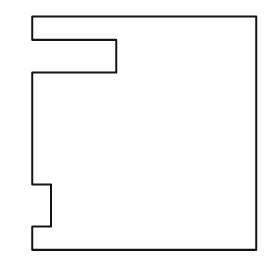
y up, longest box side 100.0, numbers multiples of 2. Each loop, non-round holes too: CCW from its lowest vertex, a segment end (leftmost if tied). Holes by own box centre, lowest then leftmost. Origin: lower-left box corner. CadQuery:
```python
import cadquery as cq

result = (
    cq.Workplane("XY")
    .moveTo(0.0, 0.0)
    .lineTo(96.0, 0.0)
    .lineTo(96.0, 100.0)
    .lineTo(0.0, 100.0)
    .lineTo(0.0, 90.0)
    .lineTo(36.0, 90.0)
    .lineTo(36.0, 76.0)
    .lineTo(0.0, 76.0)
    .lineTo(0.0, 28.0)
    .lineTo(8.0, 28.0)
    .lineTo(8.0, 10.0)
    .lineTo(0.0, 10.0)
    .close()
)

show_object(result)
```